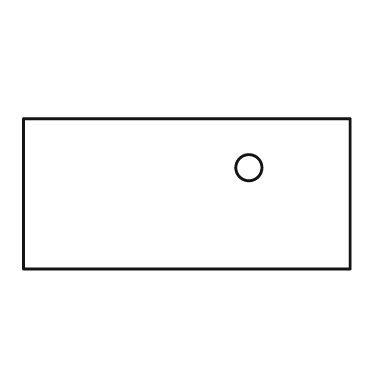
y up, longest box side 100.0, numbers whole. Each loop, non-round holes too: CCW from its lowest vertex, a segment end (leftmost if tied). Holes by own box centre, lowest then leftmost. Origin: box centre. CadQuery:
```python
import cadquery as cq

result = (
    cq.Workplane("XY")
    .moveTo(-50.0, -23.0)
    .lineTo(50.0, -23.0)
    .lineTo(50.0, 23.0)
    .lineTo(-50.0, 23.0)
    .close()
    .moveTo(19.0, 8.0)
    .circle(4.0)
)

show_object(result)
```